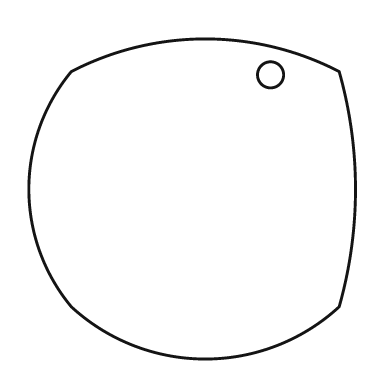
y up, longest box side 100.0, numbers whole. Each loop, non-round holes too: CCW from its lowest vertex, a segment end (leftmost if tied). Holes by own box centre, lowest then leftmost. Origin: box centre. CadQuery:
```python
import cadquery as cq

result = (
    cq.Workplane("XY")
    .moveTo(-37.0, -33.0)
    .threePointArc((4.0, -49.0), (45.0, -33.0))
    .threePointArc((50.0, 3.0), (45.0, 39.0))
    .threePointArc((4.0, 49.0), (-37.0, 39.0))
    .threePointArc((-50.0, 3.0), (-37.0, -33.0))
    .close()
    .moveTo(24.0, 38.0)
    .circle(4.0)
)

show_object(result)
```